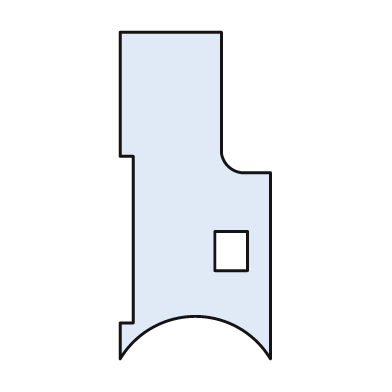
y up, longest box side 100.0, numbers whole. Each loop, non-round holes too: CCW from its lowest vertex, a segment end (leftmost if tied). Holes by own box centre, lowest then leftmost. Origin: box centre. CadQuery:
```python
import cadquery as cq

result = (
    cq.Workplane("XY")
    .moveTo(-23.0, -50.0)
    .threePointArc((0.0, -37.0), (23.0, -50.0))
    .lineTo(23.0, 7.0)
    .lineTo(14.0, 7.0)
    .threePointArc((10.0, 9.0), (8.0, 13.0))
    .lineTo(8.0, 50.0)
    .lineTo(-23.0, 50.0)
    .lineTo(-23.0, 12.0)
    .lineTo(-19.0, 12.0)
    .lineTo(-19.0, -39.0)
    .lineTo(-23.0, -39.0)
    .close()
    .moveTo(6.0, -23.0)
    .lineTo(16.0, -23.0)
    .lineTo(16.0, -11.0)
    .lineTo(6.0, -11.0)
    .close()
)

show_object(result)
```